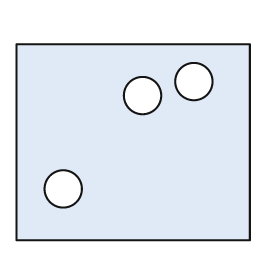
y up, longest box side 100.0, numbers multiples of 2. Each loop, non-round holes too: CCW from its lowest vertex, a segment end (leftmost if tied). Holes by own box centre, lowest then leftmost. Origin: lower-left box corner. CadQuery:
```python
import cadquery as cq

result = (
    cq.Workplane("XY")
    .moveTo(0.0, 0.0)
    .lineTo(100.0, 0.0)
    .lineTo(100.0, 84.0)
    .lineTo(0.0, 84.0)
    .close()
    .moveTo(20.0, 22.0)
    .circle(8.0)
    .moveTo(54.0, 62.0)
    .circle(8.0)
    .moveTo(76.0, 68.0)
    .circle(8.0)
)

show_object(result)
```